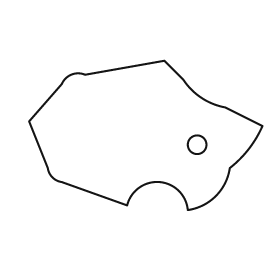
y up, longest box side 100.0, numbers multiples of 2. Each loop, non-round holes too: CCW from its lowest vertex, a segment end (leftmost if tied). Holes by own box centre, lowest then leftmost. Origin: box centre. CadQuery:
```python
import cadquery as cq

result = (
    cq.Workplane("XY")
    .moveTo(18.0, -32.0)
    .threePointArc((30.0, -26.0), (36.0, -14.0))
    .threePointArc((44.0, -6.0), (50.0, 4.0))
    .lineTo(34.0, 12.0)
    .threePointArc((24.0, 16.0), (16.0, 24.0))
    .lineTo(8.0, 32.0)
    .lineTo(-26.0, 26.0)
    .threePointArc((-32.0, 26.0), (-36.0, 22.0))
    .lineTo(-50.0, 6.0)
    .lineTo(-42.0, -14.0)
    .threePointArc((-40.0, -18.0), (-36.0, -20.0))
    .lineTo(-8.0, -30.0)
    .threePointArc((6.0, -20.0), (18.0, -32.0))
    .close()
    .moveTo(22.0, -4.0)
    .circle(4.0)
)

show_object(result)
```